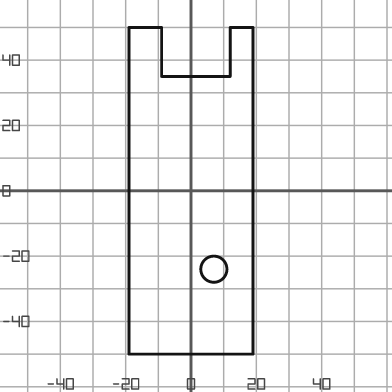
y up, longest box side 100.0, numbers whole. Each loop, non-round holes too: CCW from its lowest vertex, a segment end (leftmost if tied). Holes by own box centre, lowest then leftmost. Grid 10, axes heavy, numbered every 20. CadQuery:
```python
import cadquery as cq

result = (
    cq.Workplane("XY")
    .moveTo(-19.0, -50.0)
    .lineTo(19.0, -50.0)
    .lineTo(19.0, 50.0)
    .lineTo(12.0, 50.0)
    .lineTo(12.0, 35.0)
    .lineTo(-9.0, 35.0)
    .lineTo(-9.0, 50.0)
    .lineTo(-19.0, 50.0)
    .close()
    .moveTo(7.0, -24.0)
    .circle(4.0)
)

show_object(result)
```